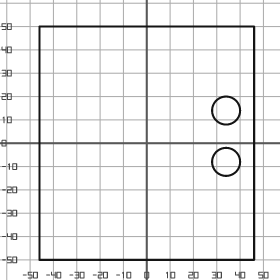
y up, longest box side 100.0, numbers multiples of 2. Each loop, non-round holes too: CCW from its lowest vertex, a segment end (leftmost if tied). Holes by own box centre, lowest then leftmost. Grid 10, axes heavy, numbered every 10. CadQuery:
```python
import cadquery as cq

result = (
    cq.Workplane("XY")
    .moveTo(-46.0, -50.0)
    .lineTo(46.0, -50.0)
    .lineTo(46.0, 50.0)
    .lineTo(-46.0, 50.0)
    .close()
    .moveTo(34.0, -8.0)
    .circle(6.0)
    .moveTo(34.0, 14.0)
    .circle(6.0)
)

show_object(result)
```